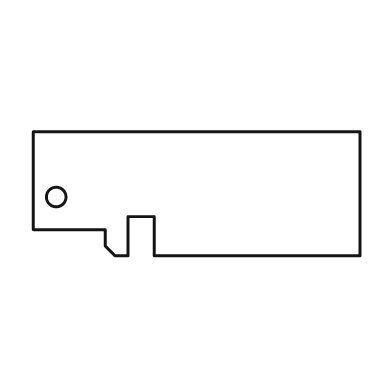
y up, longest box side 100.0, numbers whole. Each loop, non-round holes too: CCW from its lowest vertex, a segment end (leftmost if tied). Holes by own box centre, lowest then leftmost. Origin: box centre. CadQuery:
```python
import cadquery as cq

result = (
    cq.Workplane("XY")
    .moveTo(-25.0, -19.0)
    .lineTo(-21.0, -19.0)
    .lineTo(-21.0, -7.0)
    .lineTo(-13.0, -7.0)
    .lineTo(-13.0, -19.0)
    .lineTo(50.0, -19.0)
    .lineTo(50.0, 19.0)
    .lineTo(-50.0, 19.0)
    .lineTo(-50.0, -11.0)
    .lineTo(-28.0, -11.0)
    .lineTo(-28.0, -16.0)
    .close()
    .moveTo(-43.0, -1.0)
    .circle(3.0)
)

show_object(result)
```